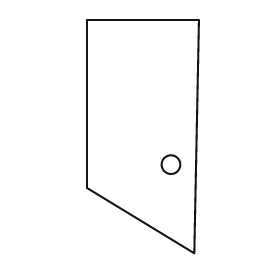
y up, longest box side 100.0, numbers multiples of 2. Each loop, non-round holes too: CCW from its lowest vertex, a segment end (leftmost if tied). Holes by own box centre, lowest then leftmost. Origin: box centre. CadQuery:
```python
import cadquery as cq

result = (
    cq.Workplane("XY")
    .moveTo(22.0, -50.0)
    .lineTo(24.0, 50.0)
    .lineTo(-24.0, 50.0)
    .lineTo(-24.0, -22.0)
    .close()
    .moveTo(12.0, -12.0)
    .circle(4.0)
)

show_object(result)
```